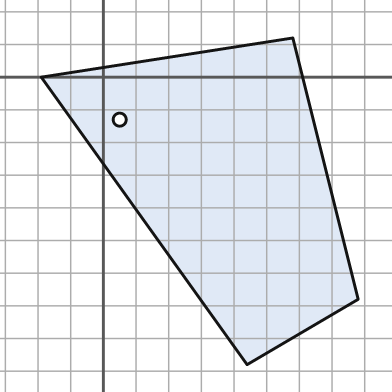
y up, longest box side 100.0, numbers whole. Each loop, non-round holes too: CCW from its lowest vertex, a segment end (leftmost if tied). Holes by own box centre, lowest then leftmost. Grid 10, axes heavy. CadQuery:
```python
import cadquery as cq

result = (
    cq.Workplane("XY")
    .moveTo(44.0, -88.0)
    .lineTo(78.0, -68.0)
    .lineTo(58.0, 12.0)
    .lineTo(-19.0, 0.0)
    .close()
    .moveTo(5.0, -13.0)
    .circle(2.0)
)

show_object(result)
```